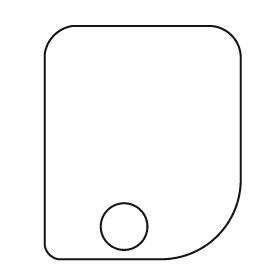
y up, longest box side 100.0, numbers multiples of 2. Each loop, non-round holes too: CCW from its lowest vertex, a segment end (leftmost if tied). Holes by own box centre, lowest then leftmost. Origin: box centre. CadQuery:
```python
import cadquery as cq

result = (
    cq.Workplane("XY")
    .moveTo(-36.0, -50.0)
    .lineTo(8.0, -50.0)
    .threePointArc((32.0, -40.0), (42.0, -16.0))
    .lineTo(42.0, 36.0)
    .threePointArc((38.0, 46.0), (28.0, 50.0))
    .lineTo(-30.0, 50.0)
    .threePointArc((-38.0, 46.0), (-42.0, 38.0))
    .lineTo(-42.0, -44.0)
    .threePointArc((-40.0, -48.0), (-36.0, -50.0))
    .close()
    .moveTo(-8.0, -36.0)
    .circle(10.0)
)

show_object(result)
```